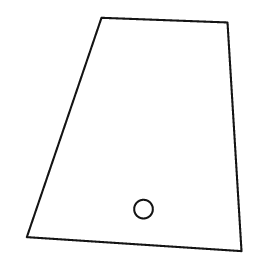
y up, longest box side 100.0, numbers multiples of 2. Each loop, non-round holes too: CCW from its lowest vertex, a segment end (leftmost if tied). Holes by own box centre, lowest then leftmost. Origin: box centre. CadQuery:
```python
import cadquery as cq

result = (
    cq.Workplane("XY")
    .moveTo(46.0, -50.0)
    .lineTo(40.0, 48.0)
    .lineTo(-14.0, 50.0)
    .lineTo(-46.0, -44.0)
    .close()
    .moveTo(4.0, -32.0)
    .circle(4.0)
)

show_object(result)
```